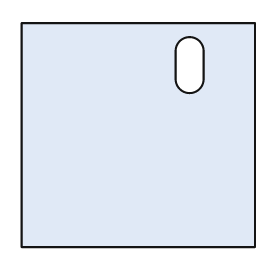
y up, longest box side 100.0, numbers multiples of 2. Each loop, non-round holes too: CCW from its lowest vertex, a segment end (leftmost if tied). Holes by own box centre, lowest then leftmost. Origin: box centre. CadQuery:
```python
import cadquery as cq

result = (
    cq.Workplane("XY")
    .moveTo(-50.0, -48.0)
    .lineTo(50.0, -48.0)
    .lineTo(50.0, 48.0)
    .lineTo(-50.0, 48.0)
    .close()
    .moveTo(16.0, 24.0)
    .threePointArc((22.0, 18.0), (28.0, 24.0))
    .lineTo(28.0, 36.0)
    .threePointArc((22.0, 42.0), (16.0, 36.0))
    .close()
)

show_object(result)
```